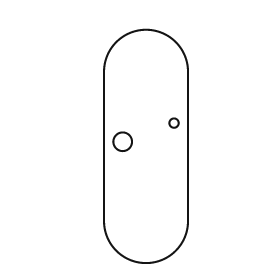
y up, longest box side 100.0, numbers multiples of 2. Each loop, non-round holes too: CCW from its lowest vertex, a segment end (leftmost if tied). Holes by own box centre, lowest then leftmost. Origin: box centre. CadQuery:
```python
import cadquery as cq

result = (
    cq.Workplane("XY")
    .moveTo(-18.0, -32.0)
    .threePointArc((0.0, -50.0), (18.0, -32.0))
    .lineTo(18.0, 32.0)
    .threePointArc((0.0, 50.0), (-18.0, 32.0))
    .close()
    .moveTo(-10.0, 2.0)
    .circle(4.0)
    .moveTo(12.0, 10.0)
    .circle(2.0)
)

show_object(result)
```